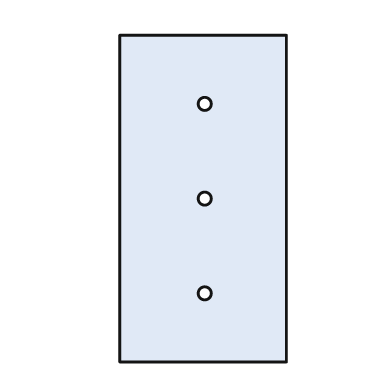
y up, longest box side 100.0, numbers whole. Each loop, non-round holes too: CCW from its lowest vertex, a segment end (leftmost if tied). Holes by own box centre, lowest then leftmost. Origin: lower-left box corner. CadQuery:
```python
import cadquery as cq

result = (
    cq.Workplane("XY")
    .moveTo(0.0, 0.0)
    .lineTo(51.0, 0.0)
    .lineTo(51.0, 100.0)
    .lineTo(0.0, 100.0)
    .close()
    .moveTo(26.0, 21.0)
    .circle(2.0)
    .moveTo(26.0, 50.0)
    .circle(2.0)
    .moveTo(26.0, 79.0)
    .circle(2.0)
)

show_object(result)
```